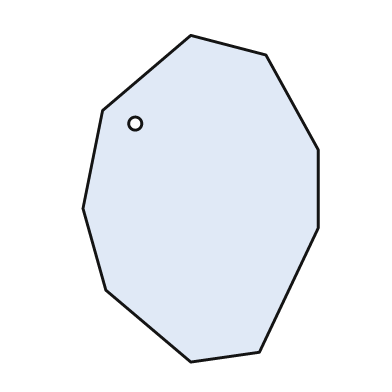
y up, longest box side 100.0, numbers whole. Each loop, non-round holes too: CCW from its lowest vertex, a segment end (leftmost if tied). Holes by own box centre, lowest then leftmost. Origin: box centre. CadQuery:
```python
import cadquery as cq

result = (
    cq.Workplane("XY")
    .moveTo(-3.0, -50.0)
    .lineTo(18.0, -47.0)
    .lineTo(36.0, -9.0)
    .lineTo(36.0, 15.0)
    .lineTo(20.0, 44.0)
    .lineTo(-3.0, 50.0)
    .lineTo(-30.0, 27.0)
    .lineTo(-36.0, -3.0)
    .lineTo(-29.0, -28.0)
    .close()
    .moveTo(-20.0, 23.0)
    .circle(2.0)
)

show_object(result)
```